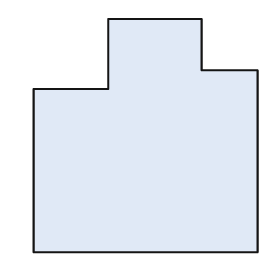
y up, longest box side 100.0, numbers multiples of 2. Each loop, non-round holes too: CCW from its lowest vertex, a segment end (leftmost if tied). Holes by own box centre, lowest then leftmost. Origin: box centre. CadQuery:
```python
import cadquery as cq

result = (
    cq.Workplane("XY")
    .moveTo(-48.0, -50.0)
    .lineTo(48.0, -50.0)
    .lineTo(48.0, 28.0)
    .lineTo(24.0, 28.0)
    .lineTo(24.0, 50.0)
    .lineTo(-16.0, 50.0)
    .lineTo(-16.0, 20.0)
    .lineTo(-48.0, 20.0)
    .close()
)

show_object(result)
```